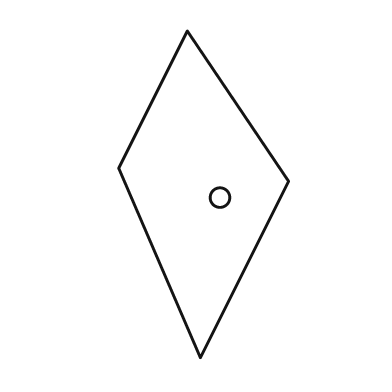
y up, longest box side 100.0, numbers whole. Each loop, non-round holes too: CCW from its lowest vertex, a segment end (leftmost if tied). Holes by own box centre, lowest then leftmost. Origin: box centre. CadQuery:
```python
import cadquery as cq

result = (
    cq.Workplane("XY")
    .moveTo(-1.0, -50.0)
    .lineTo(26.0, 4.0)
    .lineTo(-5.0, 50.0)
    .lineTo(-26.0, 8.0)
    .close()
    .moveTo(5.0, -1.0)
    .circle(3.0)
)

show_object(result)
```